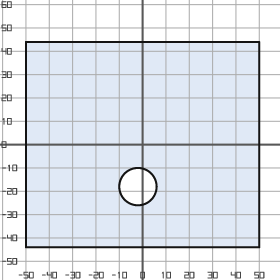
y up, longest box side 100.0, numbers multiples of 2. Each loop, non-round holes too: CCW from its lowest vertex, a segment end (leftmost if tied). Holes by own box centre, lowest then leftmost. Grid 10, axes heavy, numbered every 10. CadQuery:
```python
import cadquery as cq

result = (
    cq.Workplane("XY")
    .moveTo(-50.0, -44.0)
    .lineTo(50.0, -44.0)
    .lineTo(50.0, 44.0)
    .lineTo(-50.0, 44.0)
    .close()
    .moveTo(-2.0, -18.0)
    .circle(8.0)
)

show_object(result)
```